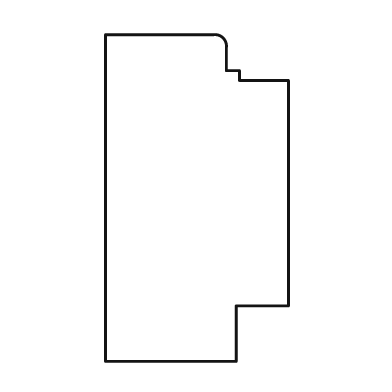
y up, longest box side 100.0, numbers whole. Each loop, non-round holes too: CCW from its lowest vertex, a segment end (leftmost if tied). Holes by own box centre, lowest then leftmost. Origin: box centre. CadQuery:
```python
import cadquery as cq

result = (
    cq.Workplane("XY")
    .moveTo(-28.0, -50.0)
    .lineTo(12.0, -50.0)
    .lineTo(12.0, -33.0)
    .lineTo(28.0, -33.0)
    .lineTo(28.0, 36.0)
    .lineTo(13.0, 36.0)
    .lineTo(13.0, 39.0)
    .lineTo(9.0, 39.0)
    .lineTo(9.0, 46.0)
    .threePointArc((8.0, 49.0), (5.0, 50.0))
    .lineTo(-28.0, 50.0)
    .close()
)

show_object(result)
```